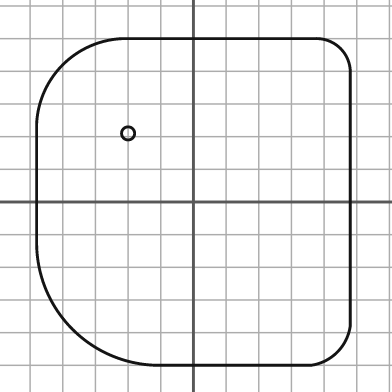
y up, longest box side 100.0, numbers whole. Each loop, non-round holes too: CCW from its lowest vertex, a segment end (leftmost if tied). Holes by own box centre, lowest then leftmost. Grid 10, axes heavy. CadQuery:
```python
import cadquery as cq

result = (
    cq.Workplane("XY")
    .moveTo(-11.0, -50.0)
    .lineTo(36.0, -50.0)
    .threePointArc((44.0, -46.0), (48.0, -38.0))
    .lineTo(48.0, 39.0)
    .threePointArc((45.0, 47.0), (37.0, 50.0))
    .lineTo(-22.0, 50.0)
    .threePointArc((-40.0, 42.0), (-48.0, 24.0))
    .lineTo(-48.0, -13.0)
    .threePointArc((-37.0, -39.0), (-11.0, -50.0))
    .close()
    .moveTo(-20.0, 21.0)
    .circle(2.0)
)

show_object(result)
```